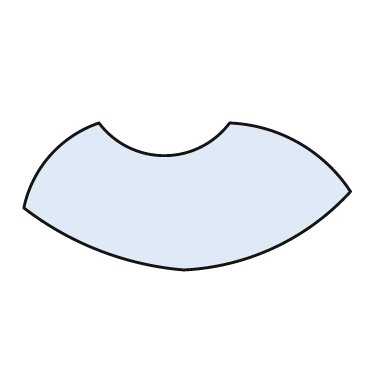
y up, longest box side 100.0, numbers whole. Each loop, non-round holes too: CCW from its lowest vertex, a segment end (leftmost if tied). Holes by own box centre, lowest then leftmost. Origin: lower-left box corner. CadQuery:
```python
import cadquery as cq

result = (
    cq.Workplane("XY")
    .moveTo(49.0, 0.0)
    .threePointArc((77.0, 7.0), (100.0, 24.0))
    .threePointArc((84.0, 39.0), (63.0, 45.0))
    .threePointArc((43.0, 35.0), (23.0, 45.0))
    .threePointArc((8.0, 35.0), (0.0, 19.0))
    .threePointArc((23.0, 6.0), (49.0, 0.0))
    .close()
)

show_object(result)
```